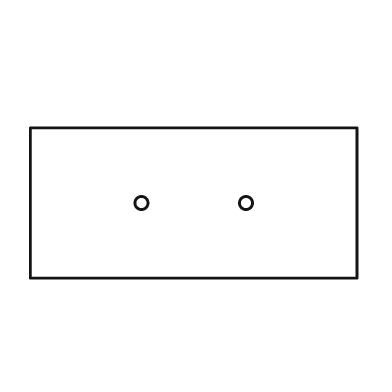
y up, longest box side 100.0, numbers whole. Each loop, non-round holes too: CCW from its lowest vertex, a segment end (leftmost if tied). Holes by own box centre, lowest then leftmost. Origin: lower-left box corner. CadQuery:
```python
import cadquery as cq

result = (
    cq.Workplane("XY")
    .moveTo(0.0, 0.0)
    .lineTo(100.0, 0.0)
    .lineTo(100.0, 46.0)
    .lineTo(0.0, 46.0)
    .close()
    .moveTo(34.0, 23.0)
    .circle(2.0)
    .moveTo(66.0, 23.0)
    .circle(2.0)
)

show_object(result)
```